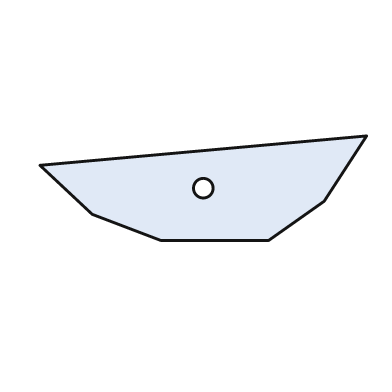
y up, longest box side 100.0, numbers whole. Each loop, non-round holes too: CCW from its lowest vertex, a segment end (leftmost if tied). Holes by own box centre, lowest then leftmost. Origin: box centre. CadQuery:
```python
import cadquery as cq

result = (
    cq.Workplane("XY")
    .moveTo(-13.0, -16.0)
    .lineTo(20.0, -16.0)
    .lineTo(37.0, -4.0)
    .lineTo(50.0, 16.0)
    .lineTo(-50.0, 7.0)
    .lineTo(-34.0, -8.0)
    .close()
    .moveTo(0.0, 0.0)
    .circle(3.0)
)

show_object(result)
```